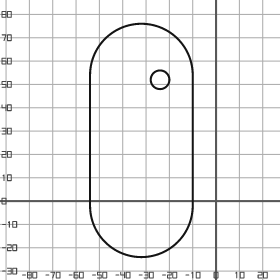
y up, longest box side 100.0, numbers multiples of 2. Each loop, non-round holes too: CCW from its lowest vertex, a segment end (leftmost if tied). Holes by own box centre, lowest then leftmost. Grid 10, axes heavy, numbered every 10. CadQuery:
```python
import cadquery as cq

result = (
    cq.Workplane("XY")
    .moveTo(-54.0, -2.0)
    .threePointArc((-32.0, -24.0), (-10.0, -2.0))
    .lineTo(-10.0, 54.0)
    .threePointArc((-32.0, 76.0), (-54.0, 54.0))
    .close()
    .moveTo(-24.0, 52.0)
    .circle(4.0)
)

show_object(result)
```